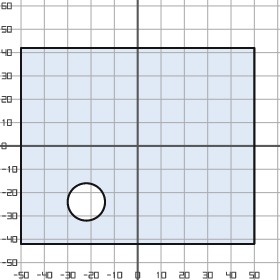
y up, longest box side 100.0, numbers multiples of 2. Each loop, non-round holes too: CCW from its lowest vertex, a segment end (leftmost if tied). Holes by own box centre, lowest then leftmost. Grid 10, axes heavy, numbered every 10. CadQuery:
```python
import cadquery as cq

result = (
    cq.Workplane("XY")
    .moveTo(-50.0, -42.0)
    .lineTo(50.0, -42.0)
    .lineTo(50.0, 42.0)
    .lineTo(-50.0, 42.0)
    .close()
    .moveTo(-22.0, -24.0)
    .circle(8.0)
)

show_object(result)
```